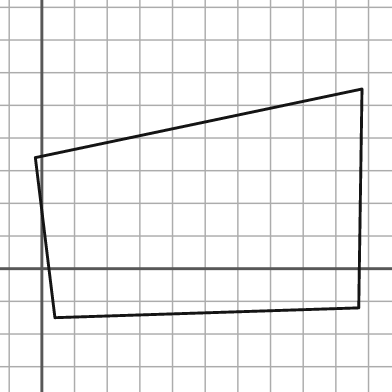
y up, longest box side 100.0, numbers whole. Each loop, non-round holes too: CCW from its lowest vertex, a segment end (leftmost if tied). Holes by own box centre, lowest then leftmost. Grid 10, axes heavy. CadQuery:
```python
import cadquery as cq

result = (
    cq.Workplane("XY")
    .moveTo(4.0, -15.0)
    .lineTo(97.0, -12.0)
    .lineTo(98.0, 55.0)
    .lineTo(-2.0, 34.0)
    .close()
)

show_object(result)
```